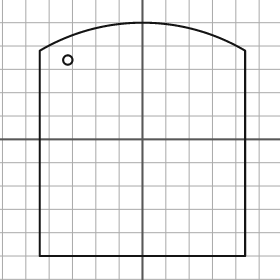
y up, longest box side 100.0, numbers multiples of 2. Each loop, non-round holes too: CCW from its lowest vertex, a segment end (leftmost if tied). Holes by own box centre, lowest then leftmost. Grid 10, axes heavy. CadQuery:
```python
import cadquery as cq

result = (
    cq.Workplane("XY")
    .moveTo(-44.0, -50.0)
    .lineTo(44.0, -50.0)
    .lineTo(44.0, 38.0)
    .threePointArc((0.0, 50.0), (-44.0, 38.0))
    .close()
    .moveTo(-32.0, 34.0)
    .circle(2.0)
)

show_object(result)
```